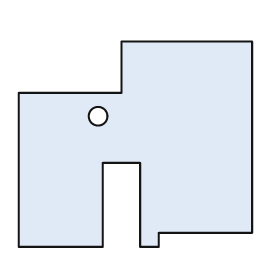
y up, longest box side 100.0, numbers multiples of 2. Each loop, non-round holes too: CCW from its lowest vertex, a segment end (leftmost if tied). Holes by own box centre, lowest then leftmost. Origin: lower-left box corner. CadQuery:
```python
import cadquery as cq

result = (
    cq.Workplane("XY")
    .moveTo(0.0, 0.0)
    .lineTo(36.0, 0.0)
    .lineTo(36.0, 36.0)
    .lineTo(52.0, 36.0)
    .lineTo(52.0, 0.0)
    .lineTo(60.0, 0.0)
    .lineTo(60.0, 6.0)
    .lineTo(100.0, 6.0)
    .lineTo(100.0, 88.0)
    .lineTo(44.0, 88.0)
    .lineTo(44.0, 66.0)
    .lineTo(0.0, 66.0)
    .close()
    .moveTo(34.0, 56.0)
    .circle(4.0)
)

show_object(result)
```